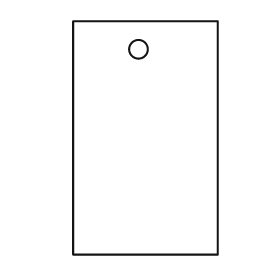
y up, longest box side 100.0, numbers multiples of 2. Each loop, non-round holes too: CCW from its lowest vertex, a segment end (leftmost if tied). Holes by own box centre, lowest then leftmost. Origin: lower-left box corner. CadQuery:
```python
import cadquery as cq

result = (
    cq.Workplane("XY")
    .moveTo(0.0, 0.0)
    .lineTo(62.0, 0.0)
    .lineTo(62.0, 100.0)
    .lineTo(0.0, 100.0)
    .close()
    .moveTo(28.0, 88.0)
    .circle(4.0)
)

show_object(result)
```